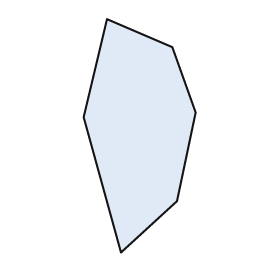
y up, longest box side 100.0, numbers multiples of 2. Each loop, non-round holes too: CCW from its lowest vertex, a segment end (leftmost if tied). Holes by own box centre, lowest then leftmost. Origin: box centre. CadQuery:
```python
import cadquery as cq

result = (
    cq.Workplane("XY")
    .moveTo(-8.0, -50.0)
    .lineTo(16.0, -28.0)
    .lineTo(24.0, 10.0)
    .lineTo(14.0, 38.0)
    .lineTo(-14.0, 50.0)
    .lineTo(-24.0, 8.0)
    .close()
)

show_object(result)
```